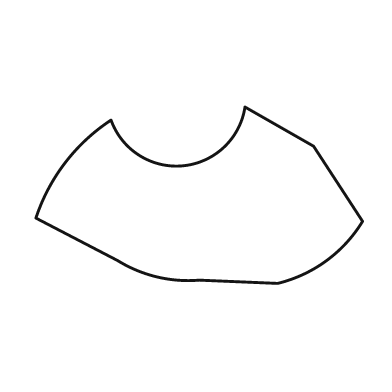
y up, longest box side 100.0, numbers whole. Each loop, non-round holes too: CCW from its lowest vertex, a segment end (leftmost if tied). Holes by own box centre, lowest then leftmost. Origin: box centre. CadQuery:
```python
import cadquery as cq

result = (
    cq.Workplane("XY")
    .moveTo(24.0, -27.0)
    .threePointArc((39.0, -20.0), (50.0, -8.0))
    .lineTo(35.0, 15.0)
    .lineTo(14.0, 27.0)
    .threePointArc((-5.0, 9.0), (-27.0, 23.0))
    .threePointArc((-41.0, 10.0), (-50.0, -7.0))
    .lineTo(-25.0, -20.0)
    .threePointArc((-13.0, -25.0), (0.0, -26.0))
    .close()
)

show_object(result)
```